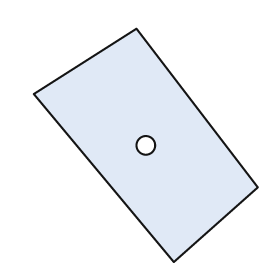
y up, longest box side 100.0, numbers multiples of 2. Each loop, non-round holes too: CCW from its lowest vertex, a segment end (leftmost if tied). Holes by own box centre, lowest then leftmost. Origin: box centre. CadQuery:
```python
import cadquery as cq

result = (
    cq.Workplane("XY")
    .moveTo(12.0, -50.0)
    .lineTo(48.0, -18.0)
    .lineTo(-4.0, 50.0)
    .lineTo(-48.0, 22.0)
    .close()
    .moveTo(0.0, 0.0)
    .circle(4.0)
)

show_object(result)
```